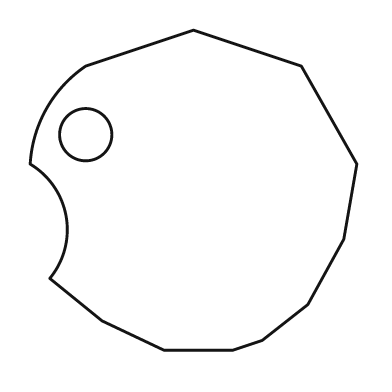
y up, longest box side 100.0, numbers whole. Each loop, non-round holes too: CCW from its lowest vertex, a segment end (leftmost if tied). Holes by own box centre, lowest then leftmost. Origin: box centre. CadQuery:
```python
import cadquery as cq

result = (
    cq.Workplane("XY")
    .moveTo(-9.0, -49.0)
    .lineTo(12.0, -49.0)
    .lineTo(21.0, -46.0)
    .lineTo(35.0, -35.0)
    .lineTo(46.0, -15.0)
    .lineTo(50.0, 8.0)
    .lineTo(33.0, 38.0)
    .lineTo(0.0, 49.0)
    .lineTo(-33.0, 38.0)
    .threePointArc((-45.0, 25.0), (-50.0, 8.0))
    .threePointArc((-39.0, -8.0), (-44.0, -27.0))
    .lineTo(-28.0, -40.0)
    .close()
    .moveTo(-33.0, 17.0)
    .circle(8.0)
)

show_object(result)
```